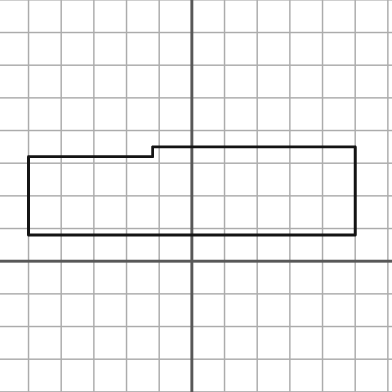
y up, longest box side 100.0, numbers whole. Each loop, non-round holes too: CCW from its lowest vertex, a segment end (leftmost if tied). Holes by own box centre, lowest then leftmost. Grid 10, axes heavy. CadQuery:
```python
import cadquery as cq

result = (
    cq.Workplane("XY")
    .moveTo(-50.0, 8.0)
    .lineTo(50.0, 8.0)
    .lineTo(50.0, 35.0)
    .lineTo(-12.0, 35.0)
    .lineTo(-12.0, 32.0)
    .lineTo(-50.0, 32.0)
    .close()
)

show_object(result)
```